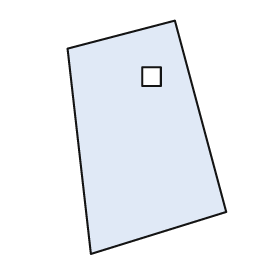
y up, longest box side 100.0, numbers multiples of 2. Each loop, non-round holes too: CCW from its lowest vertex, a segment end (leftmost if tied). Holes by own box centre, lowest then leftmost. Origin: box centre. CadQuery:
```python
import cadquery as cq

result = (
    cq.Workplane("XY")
    .moveTo(-24.0, -50.0)
    .lineTo(34.0, -32.0)
    .lineTo(12.0, 50.0)
    .lineTo(-34.0, 38.0)
    .close()
    .moveTo(-2.0, 22.0)
    .lineTo(6.0, 22.0)
    .lineTo(6.0, 30.0)
    .lineTo(-2.0, 30.0)
    .close()
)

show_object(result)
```